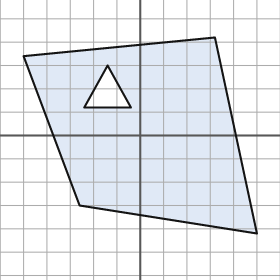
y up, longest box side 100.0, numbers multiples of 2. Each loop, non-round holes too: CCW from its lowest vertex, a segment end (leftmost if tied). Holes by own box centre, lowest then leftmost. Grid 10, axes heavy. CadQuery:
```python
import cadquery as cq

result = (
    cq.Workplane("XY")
    .moveTo(50.0, -42.0)
    .lineTo(32.0, 42.0)
    .lineTo(-50.0, 34.0)
    .lineTo(-26.0, -30.0)
    .close()
    .moveTo(-24.0, 12.0)
    .lineTo(-4.0, 12.0)
    .lineTo(-14.0, 30.0)
    .close()
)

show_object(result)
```